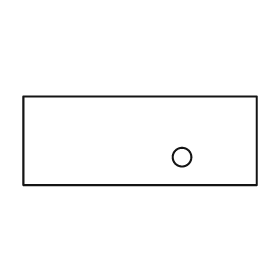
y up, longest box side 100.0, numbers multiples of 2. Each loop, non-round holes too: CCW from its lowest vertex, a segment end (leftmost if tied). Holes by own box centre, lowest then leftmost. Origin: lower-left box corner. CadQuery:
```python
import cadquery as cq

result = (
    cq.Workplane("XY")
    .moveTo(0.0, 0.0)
    .lineTo(100.0, 0.0)
    .lineTo(100.0, 38.0)
    .lineTo(0.0, 38.0)
    .close()
    .moveTo(68.0, 12.0)
    .circle(4.0)
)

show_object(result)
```